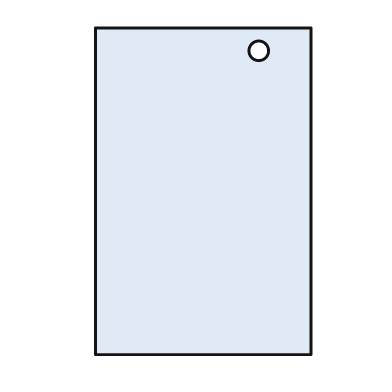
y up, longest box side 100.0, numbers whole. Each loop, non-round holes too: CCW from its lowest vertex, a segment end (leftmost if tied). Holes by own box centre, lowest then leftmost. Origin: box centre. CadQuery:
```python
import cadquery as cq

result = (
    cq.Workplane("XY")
    .moveTo(-33.0, -50.0)
    .lineTo(33.0, -50.0)
    .lineTo(33.0, 50.0)
    .lineTo(-33.0, 50.0)
    .close()
    .moveTo(17.0, 43.0)
    .circle(3.0)
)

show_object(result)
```